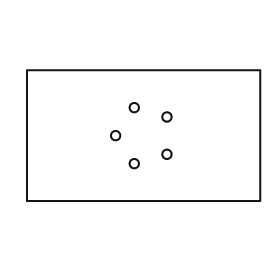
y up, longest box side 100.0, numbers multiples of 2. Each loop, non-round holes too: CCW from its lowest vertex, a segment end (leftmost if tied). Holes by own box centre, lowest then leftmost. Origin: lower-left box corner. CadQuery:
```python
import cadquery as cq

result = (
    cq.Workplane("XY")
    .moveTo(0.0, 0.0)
    .lineTo(100.0, 0.0)
    .lineTo(100.0, 56.0)
    .lineTo(0.0, 56.0)
    .close()
    .moveTo(46.0, 16.0)
    .circle(2.0)
    .moveTo(60.0, 20.0)
    .circle(2.0)
    .moveTo(38.0, 28.0)
    .circle(2.0)
    .moveTo(60.0, 36.0)
    .circle(2.0)
    .moveTo(46.0, 40.0)
    .circle(2.0)
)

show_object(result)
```